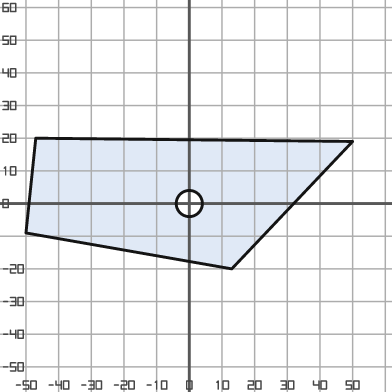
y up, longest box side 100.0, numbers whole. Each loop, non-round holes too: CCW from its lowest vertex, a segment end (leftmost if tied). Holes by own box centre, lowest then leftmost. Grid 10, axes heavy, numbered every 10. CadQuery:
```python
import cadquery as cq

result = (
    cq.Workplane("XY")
    .moveTo(13.0, -20.0)
    .lineTo(50.0, 19.0)
    .lineTo(-47.0, 20.0)
    .lineTo(-50.0, -9.0)
    .close()
    .moveTo(0.0, 0.0)
    .circle(4.0)
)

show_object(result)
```